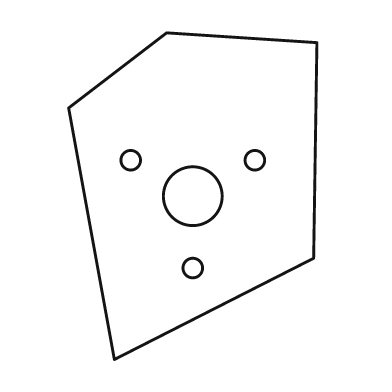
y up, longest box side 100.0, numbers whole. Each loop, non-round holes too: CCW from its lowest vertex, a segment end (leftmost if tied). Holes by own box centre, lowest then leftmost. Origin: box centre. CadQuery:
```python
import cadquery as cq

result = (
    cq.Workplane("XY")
    .moveTo(-24.0, -50.0)
    .lineTo(37.0, -19.0)
    .lineTo(38.0, 47.0)
    .lineTo(-8.0, 50.0)
    .lineTo(-38.0, 27.0)
    .close()
    .moveTo(0.0, -22.0)
    .circle(3.0)
    .moveTo(0.0, 0.0)
    .circle(9.0)
    .moveTo(-19.0, 11.0)
    .circle(3.0)
    .moveTo(19.0, 11.0)
    .circle(3.0)
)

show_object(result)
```